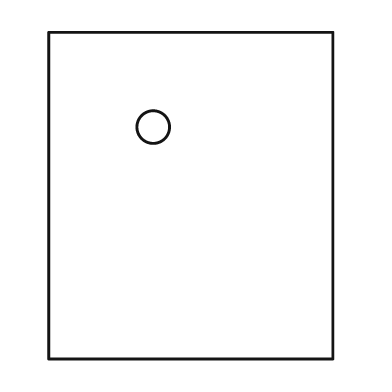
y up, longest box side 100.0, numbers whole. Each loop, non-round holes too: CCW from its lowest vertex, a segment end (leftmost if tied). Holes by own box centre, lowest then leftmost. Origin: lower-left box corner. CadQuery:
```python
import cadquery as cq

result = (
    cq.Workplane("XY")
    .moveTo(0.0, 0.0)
    .lineTo(87.0, 0.0)
    .lineTo(87.0, 100.0)
    .lineTo(0.0, 100.0)
    .close()
    .moveTo(32.0, 71.0)
    .circle(5.0)
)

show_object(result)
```